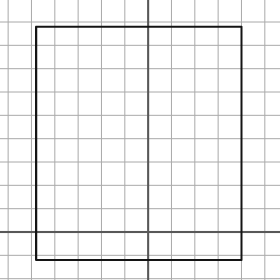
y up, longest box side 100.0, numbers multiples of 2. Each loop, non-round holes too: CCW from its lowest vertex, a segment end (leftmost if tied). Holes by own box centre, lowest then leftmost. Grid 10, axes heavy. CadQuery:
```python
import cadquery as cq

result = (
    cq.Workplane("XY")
    .moveTo(-48.0, -12.0)
    .lineTo(40.0, -12.0)
    .lineTo(40.0, 88.0)
    .lineTo(-48.0, 88.0)
    .close()
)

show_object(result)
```